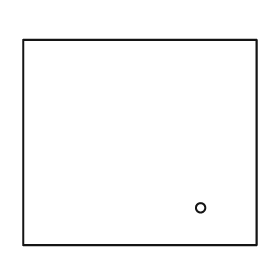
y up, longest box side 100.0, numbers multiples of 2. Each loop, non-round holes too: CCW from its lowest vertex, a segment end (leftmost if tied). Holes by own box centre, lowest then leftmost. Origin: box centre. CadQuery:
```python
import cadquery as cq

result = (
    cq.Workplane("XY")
    .moveTo(-50.0, -44.0)
    .lineTo(50.0, -44.0)
    .lineTo(50.0, 44.0)
    .lineTo(-50.0, 44.0)
    .close()
    .moveTo(26.0, -28.0)
    .circle(2.0)
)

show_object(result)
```